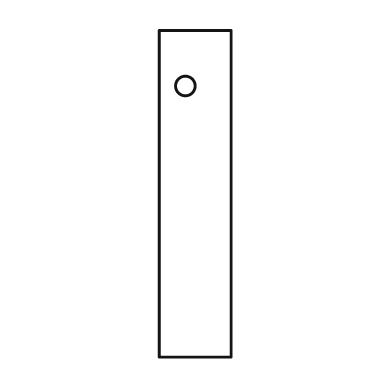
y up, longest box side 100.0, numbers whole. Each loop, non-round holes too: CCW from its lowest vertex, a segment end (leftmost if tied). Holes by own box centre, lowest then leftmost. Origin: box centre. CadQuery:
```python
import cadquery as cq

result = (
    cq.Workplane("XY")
    .moveTo(-11.0, -50.0)
    .lineTo(11.0, -50.0)
    .lineTo(11.0, 50.0)
    .lineTo(-11.0, 50.0)
    .close()
    .moveTo(-3.0, 33.0)
    .circle(3.0)
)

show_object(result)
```